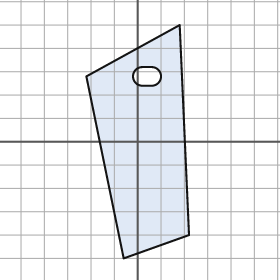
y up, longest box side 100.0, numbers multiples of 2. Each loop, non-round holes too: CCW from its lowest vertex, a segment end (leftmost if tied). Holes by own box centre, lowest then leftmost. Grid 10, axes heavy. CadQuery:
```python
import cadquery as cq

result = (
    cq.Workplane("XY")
    .moveTo(-6.0, -50.0)
    .lineTo(22.0, -40.0)
    .lineTo(18.0, 50.0)
    .lineTo(-22.0, 28.0)
    .close()
    .moveTo(2.0, 24.0)
    .lineTo(6.0, 24.0)
    .threePointArc((10.0, 28.0), (6.0, 32.0))
    .lineTo(2.0, 32.0)
    .threePointArc((-2.0, 28.0), (2.0, 24.0))
    .close()
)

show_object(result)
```